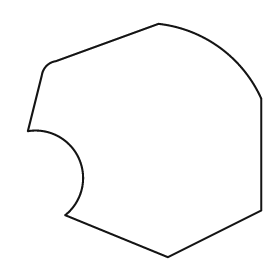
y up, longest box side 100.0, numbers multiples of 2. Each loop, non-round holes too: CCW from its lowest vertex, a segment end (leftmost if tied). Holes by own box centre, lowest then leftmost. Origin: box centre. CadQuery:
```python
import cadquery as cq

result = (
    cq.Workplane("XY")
    .moveTo(10.0, -50.0)
    .lineTo(50.0, -30.0)
    .lineTo(50.0, 18.0)
    .threePointArc((32.0, 40.0), (6.0, 50.0))
    .lineTo(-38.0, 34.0)
    .threePointArc((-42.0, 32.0), (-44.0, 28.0))
    .lineTo(-50.0, 4.0)
    .threePointArc((-28.0, -8.0), (-34.0, -32.0))
    .close()
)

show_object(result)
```